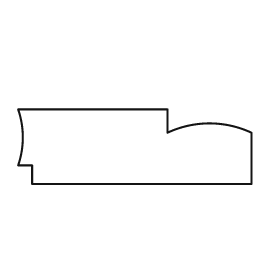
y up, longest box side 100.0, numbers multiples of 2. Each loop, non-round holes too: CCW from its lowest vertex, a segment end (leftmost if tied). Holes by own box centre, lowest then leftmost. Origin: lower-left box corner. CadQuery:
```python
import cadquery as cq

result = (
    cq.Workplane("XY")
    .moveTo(6.0, 0.0)
    .lineTo(100.0, 0.0)
    .lineTo(100.0, 22.0)
    .threePointArc((82.0, 26.0), (64.0, 22.0))
    .lineTo(64.0, 32.0)
    .lineTo(0.0, 32.0)
    .threePointArc((2.0, 20.0), (0.0, 8.0))
    .lineTo(6.0, 8.0)
    .close()
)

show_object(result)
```